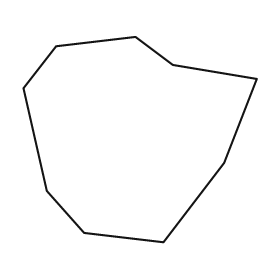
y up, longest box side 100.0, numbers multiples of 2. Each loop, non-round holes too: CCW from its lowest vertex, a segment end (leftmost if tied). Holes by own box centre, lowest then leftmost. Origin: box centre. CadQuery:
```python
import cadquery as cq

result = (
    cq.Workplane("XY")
    .moveTo(10.0, -44.0)
    .lineTo(36.0, -10.0)
    .lineTo(50.0, 26.0)
    .lineTo(14.0, 32.0)
    .lineTo(-2.0, 44.0)
    .lineTo(-36.0, 40.0)
    .lineTo(-50.0, 22.0)
    .lineTo(-40.0, -22.0)
    .lineTo(-24.0, -40.0)
    .close()
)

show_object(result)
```